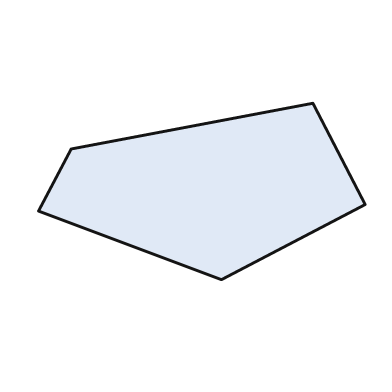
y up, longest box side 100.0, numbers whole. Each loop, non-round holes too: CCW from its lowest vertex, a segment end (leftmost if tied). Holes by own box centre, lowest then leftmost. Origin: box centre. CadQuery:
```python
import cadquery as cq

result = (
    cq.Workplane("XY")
    .moveTo(6.0, -27.0)
    .lineTo(50.0, -4.0)
    .lineTo(34.0, 27.0)
    .lineTo(-40.0, 13.0)
    .lineTo(-50.0, -6.0)
    .close()
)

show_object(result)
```